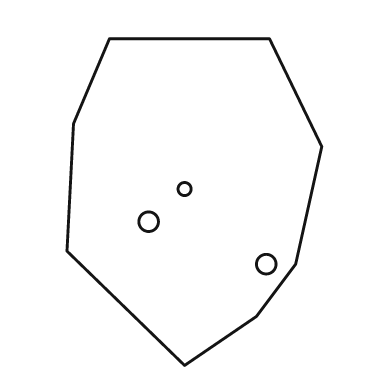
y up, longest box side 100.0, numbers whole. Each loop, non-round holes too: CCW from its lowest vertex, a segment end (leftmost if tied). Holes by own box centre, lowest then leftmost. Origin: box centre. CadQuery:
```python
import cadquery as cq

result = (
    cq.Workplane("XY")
    .moveTo(-3.0, -50.0)
    .lineTo(19.0, -35.0)
    .lineTo(31.0, -19.0)
    .lineTo(39.0, 17.0)
    .lineTo(23.0, 50.0)
    .lineTo(-26.0, 50.0)
    .lineTo(-37.0, 24.0)
    .lineTo(-39.0, -15.0)
    .close()
    .moveTo(22.0, -19.0)
    .circle(3.0)
    .moveTo(-14.0, -6.0)
    .circle(3.0)
    .moveTo(-3.0, 4.0)
    .circle(2.0)
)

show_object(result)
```